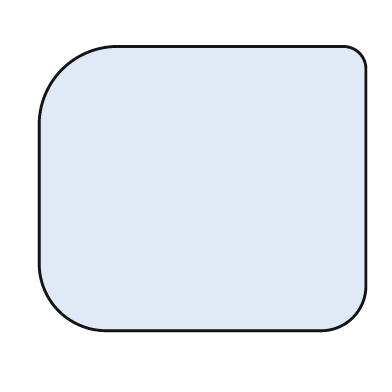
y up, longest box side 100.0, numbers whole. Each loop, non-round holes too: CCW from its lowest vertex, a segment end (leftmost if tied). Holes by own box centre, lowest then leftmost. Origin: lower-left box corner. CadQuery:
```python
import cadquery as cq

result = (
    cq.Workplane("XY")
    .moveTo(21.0, 0.0)
    .lineTo(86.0, 0.0)
    .threePointArc((96.0, 4.0), (100.0, 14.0))
    .lineTo(100.0, 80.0)
    .threePointArc((98.0, 85.0), (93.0, 87.0))
    .lineTo(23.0, 87.0)
    .threePointArc((7.0, 80.0), (0.0, 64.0))
    .lineTo(0.0, 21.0)
    .threePointArc((6.0, 6.0), (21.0, 0.0))
    .close()
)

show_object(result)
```